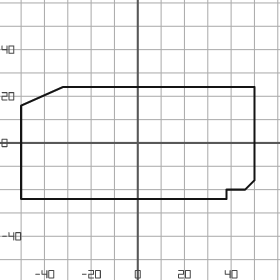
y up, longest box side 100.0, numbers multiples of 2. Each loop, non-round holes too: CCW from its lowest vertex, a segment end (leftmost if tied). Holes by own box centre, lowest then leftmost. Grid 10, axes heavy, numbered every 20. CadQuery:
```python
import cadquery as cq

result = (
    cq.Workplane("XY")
    .moveTo(-50.0, -24.0)
    .lineTo(38.0, -24.0)
    .lineTo(38.0, -20.0)
    .lineTo(46.0, -20.0)
    .lineTo(50.0, -16.0)
    .lineTo(50.0, 24.0)
    .lineTo(-32.0, 24.0)
    .lineTo(-50.0, 16.0)
    .close()
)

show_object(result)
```